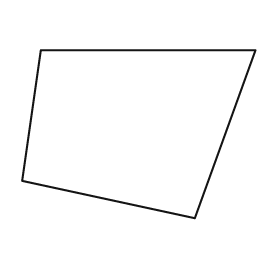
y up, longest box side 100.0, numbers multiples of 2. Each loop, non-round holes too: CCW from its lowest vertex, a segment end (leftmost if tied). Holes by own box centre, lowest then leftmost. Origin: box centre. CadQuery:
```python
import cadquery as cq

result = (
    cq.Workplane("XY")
    .moveTo(24.0, -36.0)
    .lineTo(50.0, 36.0)
    .lineTo(-42.0, 36.0)
    .lineTo(-50.0, -20.0)
    .close()
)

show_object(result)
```